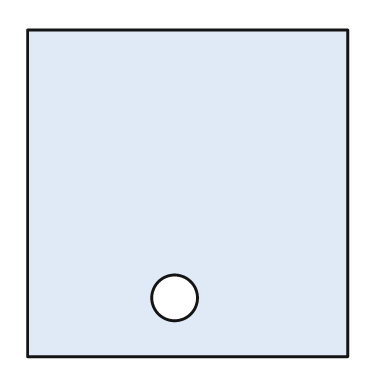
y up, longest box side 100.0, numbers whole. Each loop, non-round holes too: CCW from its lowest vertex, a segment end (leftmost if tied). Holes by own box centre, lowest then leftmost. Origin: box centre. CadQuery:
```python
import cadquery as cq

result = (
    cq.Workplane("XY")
    .moveTo(-49.0, -50.0)
    .lineTo(49.0, -50.0)
    .lineTo(49.0, 50.0)
    .lineTo(-49.0, 50.0)
    .close()
    .moveTo(-4.0, -32.0)
    .circle(7.0)
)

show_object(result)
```